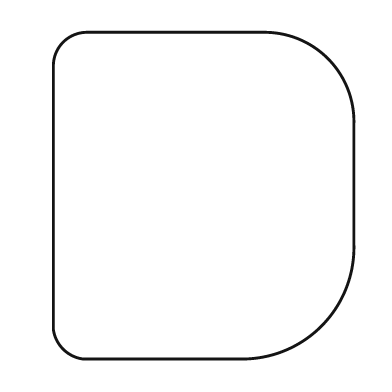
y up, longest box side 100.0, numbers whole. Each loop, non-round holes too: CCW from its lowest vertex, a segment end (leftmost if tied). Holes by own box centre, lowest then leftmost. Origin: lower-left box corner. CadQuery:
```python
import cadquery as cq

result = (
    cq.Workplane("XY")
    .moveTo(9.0, 0.0)
    .lineTo(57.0, 0.0)
    .threePointArc((82.0, 10.0), (92.0, 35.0))
    .lineTo(92.0, 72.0)
    .threePointArc((84.0, 92.0), (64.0, 100.0))
    .lineTo(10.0, 100.0)
    .threePointArc((3.0, 97.0), (0.0, 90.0))
    .lineTo(0.0, 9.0)
    .threePointArc((3.0, 3.0), (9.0, 0.0))
    .close()
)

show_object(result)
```